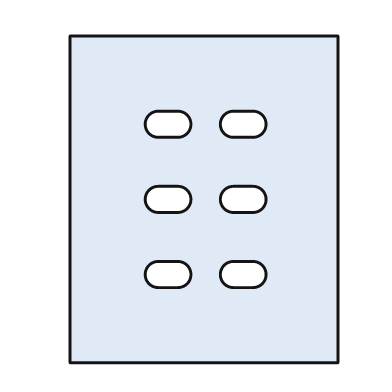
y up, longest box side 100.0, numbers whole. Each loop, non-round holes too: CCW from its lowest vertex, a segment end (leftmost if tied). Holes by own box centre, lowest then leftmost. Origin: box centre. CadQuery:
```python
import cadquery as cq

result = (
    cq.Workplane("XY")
    .moveTo(-41.0, -50.0)
    .lineTo(41.0, -50.0)
    .lineTo(41.0, 50.0)
    .lineTo(-41.0, 50.0)
    .close()
    .moveTo(-14.0, -27.0)
    .lineTo(-8.0, -27.0)
    .threePointArc((-4.0, -23.0), (-8.0, -19.0))
    .lineTo(-14.0, -19.0)
    .threePointArc((-18.0, -23.0), (-14.0, -27.0))
    .close()
    .moveTo(9.0, -27.0)
    .lineTo(15.0, -27.0)
    .threePointArc((19.0, -23.0), (15.0, -19.0))
    .lineTo(9.0, -19.0)
    .threePointArc((5.0, -23.0), (9.0, -27.0))
    .close()
    .moveTo(-14.0, -4.0)
    .lineTo(-8.0, -4.0)
    .threePointArc((-4.0, 0.0), (-8.0, 4.0))
    .lineTo(-14.0, 4.0)
    .threePointArc((-18.0, 0.0), (-14.0, -4.0))
    .close()
    .moveTo(9.0, -4.0)
    .lineTo(15.0, -4.0)
    .threePointArc((19.0, 0.0), (15.0, 4.0))
    .lineTo(9.0, 4.0)
    .threePointArc((5.0, 0.0), (9.0, -4.0))
    .close()
    .moveTo(-14.0, 19.0)
    .lineTo(-8.0, 19.0)
    .threePointArc((-4.0, 23.0), (-8.0, 27.0))
    .lineTo(-14.0, 27.0)
    .threePointArc((-18.0, 23.0), (-14.0, 19.0))
    .close()
    .moveTo(9.0, 19.0)
    .lineTo(15.0, 19.0)
    .threePointArc((19.0, 23.0), (15.0, 27.0))
    .lineTo(9.0, 27.0)
    .threePointArc((5.0, 23.0), (9.0, 19.0))
    .close()
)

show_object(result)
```